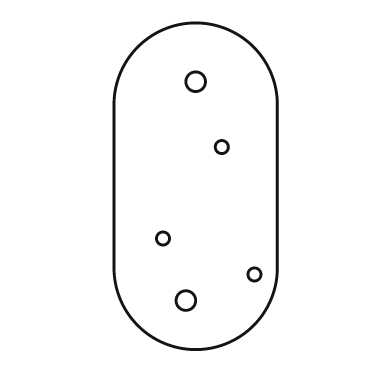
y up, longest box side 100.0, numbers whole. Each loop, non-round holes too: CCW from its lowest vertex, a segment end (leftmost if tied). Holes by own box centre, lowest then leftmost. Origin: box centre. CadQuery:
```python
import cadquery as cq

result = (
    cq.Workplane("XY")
    .moveTo(-25.0, -25.0)
    .threePointArc((0.0, -50.0), (25.0, -25.0))
    .lineTo(25.0, 25.0)
    .threePointArc((0.0, 50.0), (-25.0, 25.0))
    .close()
    .moveTo(-3.0, -35.0)
    .circle(3.0)
    .moveTo(18.0, -27.0)
    .circle(2.0)
    .moveTo(-10.0, -16.0)
    .circle(2.0)
    .moveTo(8.0, 12.0)
    .circle(2.0)
    .moveTo(0.0, 32.0)
    .circle(3.0)
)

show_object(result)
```